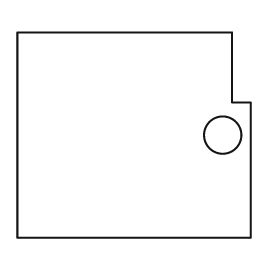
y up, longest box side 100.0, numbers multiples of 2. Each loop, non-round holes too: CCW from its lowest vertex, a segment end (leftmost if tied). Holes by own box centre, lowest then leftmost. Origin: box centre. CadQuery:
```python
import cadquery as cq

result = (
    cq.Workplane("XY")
    .moveTo(-50.0, -44.0)
    .lineTo(50.0, -44.0)
    .lineTo(50.0, 14.0)
    .lineTo(42.0, 14.0)
    .lineTo(42.0, 44.0)
    .lineTo(-50.0, 44.0)
    .close()
    .moveTo(38.0, 0.0)
    .circle(8.0)
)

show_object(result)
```